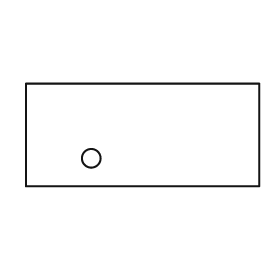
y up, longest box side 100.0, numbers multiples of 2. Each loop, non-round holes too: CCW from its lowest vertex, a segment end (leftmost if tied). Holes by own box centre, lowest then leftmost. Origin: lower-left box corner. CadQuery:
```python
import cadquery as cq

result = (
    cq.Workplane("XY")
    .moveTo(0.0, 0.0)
    .lineTo(100.0, 0.0)
    .lineTo(100.0, 44.0)
    .lineTo(0.0, 44.0)
    .close()
    .moveTo(28.0, 12.0)
    .circle(4.0)
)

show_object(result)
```